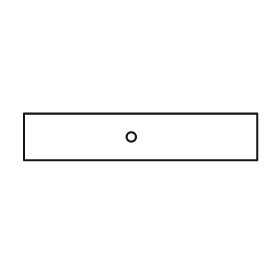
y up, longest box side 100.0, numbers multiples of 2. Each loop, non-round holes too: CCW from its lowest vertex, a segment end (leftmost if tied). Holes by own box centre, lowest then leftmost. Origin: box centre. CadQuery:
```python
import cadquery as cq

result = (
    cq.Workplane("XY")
    .moveTo(-50.0, -10.0)
    .lineTo(50.0, -10.0)
    .lineTo(50.0, 10.0)
    .lineTo(-50.0, 10.0)
    .close()
    .moveTo(-4.0, 0.0)
    .circle(2.0)
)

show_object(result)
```